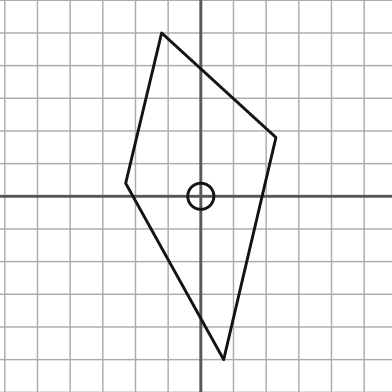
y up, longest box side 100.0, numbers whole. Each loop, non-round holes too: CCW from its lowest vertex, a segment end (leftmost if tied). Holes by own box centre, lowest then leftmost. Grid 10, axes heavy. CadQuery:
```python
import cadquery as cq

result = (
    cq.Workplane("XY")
    .moveTo(7.0, -50.0)
    .lineTo(23.0, 18.0)
    .lineTo(-12.0, 50.0)
    .lineTo(-23.0, 4.0)
    .close()
    .moveTo(0.0, 0.0)
    .circle(4.0)
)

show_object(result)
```